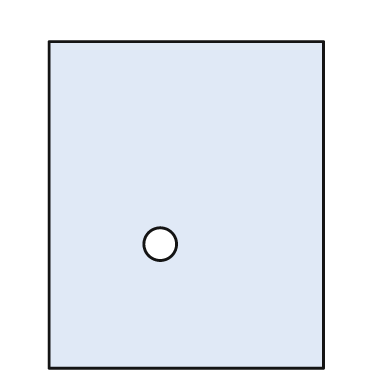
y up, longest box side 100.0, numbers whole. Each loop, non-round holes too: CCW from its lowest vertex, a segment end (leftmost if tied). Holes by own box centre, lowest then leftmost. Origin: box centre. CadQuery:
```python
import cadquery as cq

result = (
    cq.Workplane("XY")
    .moveTo(-42.0, -50.0)
    .lineTo(42.0, -50.0)
    .lineTo(42.0, 50.0)
    .lineTo(-42.0, 50.0)
    .close()
    .moveTo(-8.0, -12.0)
    .circle(5.0)
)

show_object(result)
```